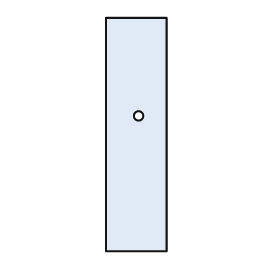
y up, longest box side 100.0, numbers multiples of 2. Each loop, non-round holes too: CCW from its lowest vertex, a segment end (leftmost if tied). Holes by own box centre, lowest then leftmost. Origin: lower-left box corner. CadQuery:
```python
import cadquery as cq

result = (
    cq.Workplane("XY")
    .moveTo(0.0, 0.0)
    .lineTo(26.0, 0.0)
    .lineTo(26.0, 100.0)
    .lineTo(0.0, 100.0)
    .close()
    .moveTo(14.0, 58.0)
    .circle(2.0)
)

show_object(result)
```